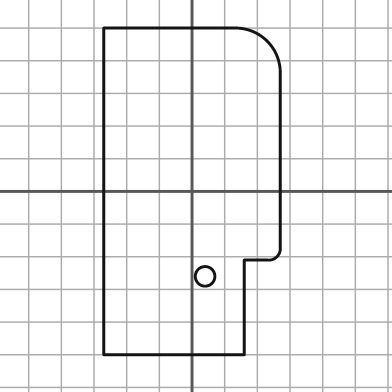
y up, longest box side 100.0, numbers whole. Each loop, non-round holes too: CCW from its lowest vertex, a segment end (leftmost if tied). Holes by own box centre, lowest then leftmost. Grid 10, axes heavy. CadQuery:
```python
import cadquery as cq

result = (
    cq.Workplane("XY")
    .moveTo(-27.0, -50.0)
    .lineTo(16.0, -50.0)
    .lineTo(16.0, -21.0)
    .lineTo(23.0, -21.0)
    .threePointArc((26.0, -20.0), (27.0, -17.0))
    .lineTo(27.0, 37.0)
    .threePointArc((23.0, 46.0), (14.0, 50.0))
    .lineTo(-27.0, 50.0)
    .close()
    .moveTo(4.0, -26.0)
    .circle(3.0)
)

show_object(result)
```